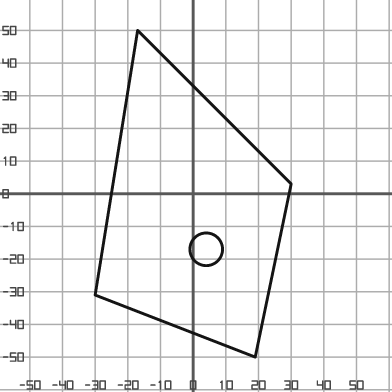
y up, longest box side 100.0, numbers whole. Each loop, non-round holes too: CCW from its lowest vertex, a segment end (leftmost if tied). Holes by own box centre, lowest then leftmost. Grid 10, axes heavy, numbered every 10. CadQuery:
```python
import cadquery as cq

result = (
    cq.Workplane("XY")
    .moveTo(19.0, -50.0)
    .lineTo(30.0, 3.0)
    .lineTo(-17.0, 50.0)
    .lineTo(-30.0, -31.0)
    .close()
    .moveTo(4.0, -17.0)
    .circle(5.0)
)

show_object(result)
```